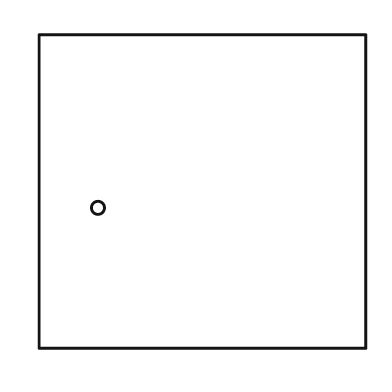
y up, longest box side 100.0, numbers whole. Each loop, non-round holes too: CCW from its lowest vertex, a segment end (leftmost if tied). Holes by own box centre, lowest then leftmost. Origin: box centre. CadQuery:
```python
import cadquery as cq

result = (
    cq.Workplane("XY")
    .moveTo(-50.0, -48.0)
    .lineTo(50.0, -48.0)
    .lineTo(50.0, 48.0)
    .lineTo(-50.0, 48.0)
    .close()
    .moveTo(-32.0, -5.0)
    .circle(2.0)
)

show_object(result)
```